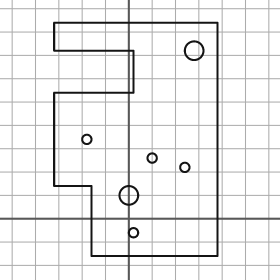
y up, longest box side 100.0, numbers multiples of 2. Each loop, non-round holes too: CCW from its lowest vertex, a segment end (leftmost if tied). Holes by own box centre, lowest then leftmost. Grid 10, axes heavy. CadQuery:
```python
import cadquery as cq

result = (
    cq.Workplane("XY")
    .moveTo(-16.0, -16.0)
    .lineTo(38.0, -16.0)
    .lineTo(38.0, 84.0)
    .lineTo(-32.0, 84.0)
    .lineTo(-32.0, 72.0)
    .lineTo(2.0, 72.0)
    .lineTo(2.0, 54.0)
    .lineTo(-32.0, 54.0)
    .lineTo(-32.0, 14.0)
    .lineTo(-16.0, 14.0)
    .close()
    .moveTo(2.0, -6.0)
    .circle(2.0)
    .moveTo(0.0, 10.0)
    .circle(4.0)
    .moveTo(24.0, 22.0)
    .circle(2.0)
    .moveTo(10.0, 26.0)
    .circle(2.0)
    .moveTo(-18.0, 34.0)
    .circle(2.0)
    .moveTo(28.0, 72.0)
    .circle(4.0)
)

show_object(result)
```